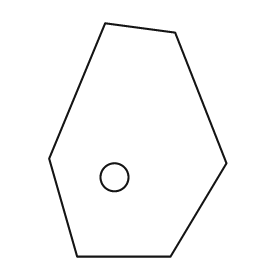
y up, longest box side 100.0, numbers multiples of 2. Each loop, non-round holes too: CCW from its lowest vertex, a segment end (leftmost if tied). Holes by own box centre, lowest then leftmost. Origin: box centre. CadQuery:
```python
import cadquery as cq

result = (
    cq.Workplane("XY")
    .moveTo(-26.0, -50.0)
    .lineTo(14.0, -50.0)
    .lineTo(38.0, -10.0)
    .lineTo(16.0, 46.0)
    .lineTo(-14.0, 50.0)
    .lineTo(-38.0, -8.0)
    .close()
    .moveTo(-10.0, -16.0)
    .circle(6.0)
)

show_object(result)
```